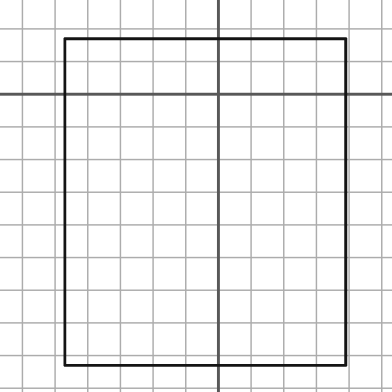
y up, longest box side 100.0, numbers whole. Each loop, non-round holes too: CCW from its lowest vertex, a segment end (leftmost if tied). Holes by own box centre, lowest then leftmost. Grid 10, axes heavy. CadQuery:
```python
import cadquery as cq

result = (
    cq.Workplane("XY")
    .moveTo(-47.0, -83.0)
    .lineTo(39.0, -83.0)
    .lineTo(39.0, 17.0)
    .lineTo(-47.0, 17.0)
    .close()
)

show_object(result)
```